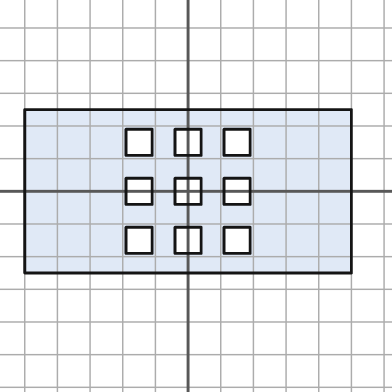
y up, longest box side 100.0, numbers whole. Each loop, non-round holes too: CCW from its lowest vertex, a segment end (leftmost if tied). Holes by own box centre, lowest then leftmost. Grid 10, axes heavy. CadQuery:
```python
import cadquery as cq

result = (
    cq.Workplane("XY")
    .moveTo(-50.0, -25.0)
    .lineTo(50.0, -25.0)
    .lineTo(50.0, 25.0)
    .lineTo(-50.0, 25.0)
    .close()
    .moveTo(-19.0, -19.0)
    .lineTo(-11.0, -19.0)
    .lineTo(-11.0, -11.0)
    .lineTo(-19.0, -11.0)
    .close()
    .moveTo(-4.0, -19.0)
    .lineTo(4.0, -19.0)
    .lineTo(4.0, -11.0)
    .lineTo(-4.0, -11.0)
    .close()
    .moveTo(11.0, -19.0)
    .lineTo(19.0, -19.0)
    .lineTo(19.0, -11.0)
    .lineTo(11.0, -11.0)
    .close()
    .moveTo(-19.0, -4.0)
    .lineTo(-11.0, -4.0)
    .lineTo(-11.0, 4.0)
    .lineTo(-19.0, 4.0)
    .close()
    .moveTo(-4.0, -4.0)
    .lineTo(4.0, -4.0)
    .lineTo(4.0, 4.0)
    .lineTo(-4.0, 4.0)
    .close()
    .moveTo(11.0, -4.0)
    .lineTo(19.0, -4.0)
    .lineTo(19.0, 4.0)
    .lineTo(11.0, 4.0)
    .close()
    .moveTo(-19.0, 11.0)
    .lineTo(-11.0, 11.0)
    .lineTo(-11.0, 19.0)
    .lineTo(-19.0, 19.0)
    .close()
    .moveTo(-4.0, 11.0)
    .lineTo(4.0, 11.0)
    .lineTo(4.0, 19.0)
    .lineTo(-4.0, 19.0)
    .close()
    .moveTo(11.0, 11.0)
    .lineTo(19.0, 11.0)
    .lineTo(19.0, 19.0)
    .lineTo(11.0, 19.0)
    .close()
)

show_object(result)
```